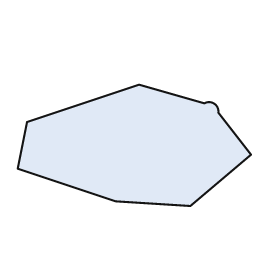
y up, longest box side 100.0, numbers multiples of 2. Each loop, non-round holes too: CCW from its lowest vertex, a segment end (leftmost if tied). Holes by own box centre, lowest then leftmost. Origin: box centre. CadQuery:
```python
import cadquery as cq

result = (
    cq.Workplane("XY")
    .moveTo(24.0, -26.0)
    .lineTo(50.0, -4.0)
    .lineTo(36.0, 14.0)
    .threePointArc((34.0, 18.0), (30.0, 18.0))
    .lineTo(2.0, 26.0)
    .lineTo(-46.0, 10.0)
    .lineTo(-50.0, -10.0)
    .lineTo(-8.0, -24.0)
    .close()
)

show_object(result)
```